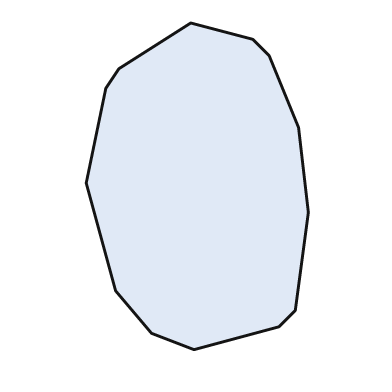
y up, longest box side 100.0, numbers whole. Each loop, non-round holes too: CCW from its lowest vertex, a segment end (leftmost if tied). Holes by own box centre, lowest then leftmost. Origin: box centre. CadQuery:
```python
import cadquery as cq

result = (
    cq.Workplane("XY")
    .moveTo(-1.0, -50.0)
    .lineTo(25.0, -43.0)
    .lineTo(30.0, -38.0)
    .lineTo(34.0, -8.0)
    .lineTo(31.0, 18.0)
    .lineTo(22.0, 40.0)
    .lineTo(17.0, 45.0)
    .lineTo(-2.0, 50.0)
    .lineTo(-24.0, 36.0)
    .lineTo(-28.0, 30.0)
    .lineTo(-34.0, 1.0)
    .lineTo(-25.0, -32.0)
    .lineTo(-14.0, -45.0)
    .close()
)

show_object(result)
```